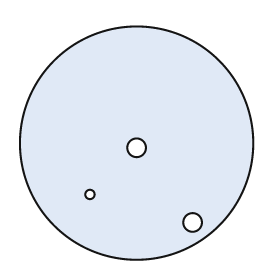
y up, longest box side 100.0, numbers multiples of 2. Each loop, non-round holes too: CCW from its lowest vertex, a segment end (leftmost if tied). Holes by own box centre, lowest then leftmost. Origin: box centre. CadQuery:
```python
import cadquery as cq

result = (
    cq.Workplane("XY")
    .moveTo(0.0, 0.0)
    .circle(50.0)
    .moveTo(24.0, -34.0)
    .circle(4.0)
    .moveTo(-20.0, -22.0)
    .circle(2.0)
    .moveTo(0.0, -2.0)
    .circle(4.0)
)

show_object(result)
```